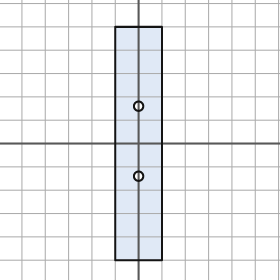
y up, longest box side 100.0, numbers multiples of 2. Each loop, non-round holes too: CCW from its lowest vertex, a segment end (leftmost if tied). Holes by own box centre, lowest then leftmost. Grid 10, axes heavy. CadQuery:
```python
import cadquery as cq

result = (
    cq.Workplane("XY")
    .moveTo(-10.0, -50.0)
    .lineTo(10.0, -50.0)
    .lineTo(10.0, 50.0)
    .lineTo(-10.0, 50.0)
    .close()
    .moveTo(0.0, -14.0)
    .circle(2.0)
    .moveTo(0.0, 16.0)
    .circle(2.0)
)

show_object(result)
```